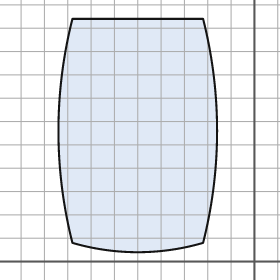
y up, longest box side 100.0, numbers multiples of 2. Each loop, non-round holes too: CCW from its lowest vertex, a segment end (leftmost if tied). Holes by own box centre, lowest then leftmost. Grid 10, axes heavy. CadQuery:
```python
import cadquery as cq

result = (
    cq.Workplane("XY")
    .moveTo(-78.0, 8.0)
    .threePointArc((-50.0, 4.0), (-22.0, 8.0))
    .threePointArc((-16.0, 56.0), (-22.0, 104.0))
    .lineTo(-78.0, 104.0)
    .threePointArc((-84.0, 56.0), (-78.0, 8.0))
    .close()
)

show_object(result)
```